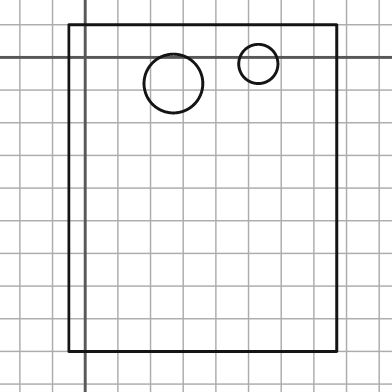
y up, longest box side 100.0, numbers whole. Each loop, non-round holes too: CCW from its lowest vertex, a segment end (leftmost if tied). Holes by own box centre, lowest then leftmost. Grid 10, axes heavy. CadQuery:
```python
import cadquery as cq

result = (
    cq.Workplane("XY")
    .moveTo(-5.0, -90.0)
    .lineTo(77.0, -90.0)
    .lineTo(77.0, 10.0)
    .lineTo(-5.0, 10.0)
    .close()
    .moveTo(27.0, -8.0)
    .circle(9.0)
    .moveTo(53.0, -2.0)
    .circle(6.0)
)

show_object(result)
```